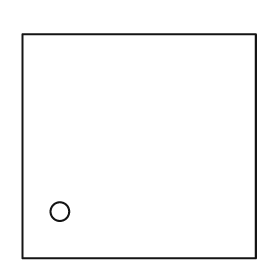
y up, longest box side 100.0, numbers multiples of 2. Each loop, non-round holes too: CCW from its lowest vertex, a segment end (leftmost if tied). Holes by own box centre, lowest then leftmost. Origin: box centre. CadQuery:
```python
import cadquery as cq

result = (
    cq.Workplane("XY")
    .moveTo(-50.0, -48.0)
    .lineTo(50.0, -48.0)
    .lineTo(50.0, 48.0)
    .lineTo(-50.0, 48.0)
    .close()
    .moveTo(-34.0, -28.0)
    .circle(4.0)
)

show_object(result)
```